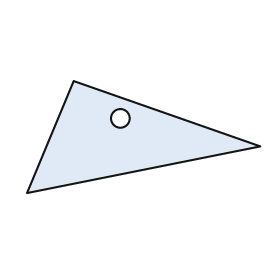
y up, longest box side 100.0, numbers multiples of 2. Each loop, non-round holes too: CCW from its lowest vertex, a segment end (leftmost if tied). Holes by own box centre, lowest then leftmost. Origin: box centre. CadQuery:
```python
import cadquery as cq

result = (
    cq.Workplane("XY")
    .moveTo(-50.0, -24.0)
    .lineTo(50.0, -4.0)
    .lineTo(-30.0, 24.0)
    .close()
    .moveTo(-10.0, 8.0)
    .circle(4.0)
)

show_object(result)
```